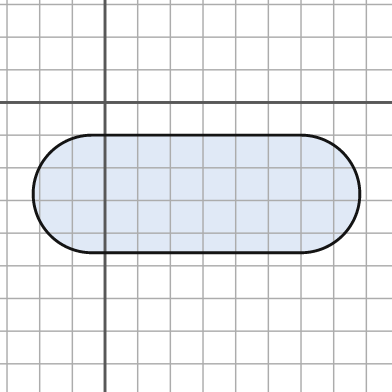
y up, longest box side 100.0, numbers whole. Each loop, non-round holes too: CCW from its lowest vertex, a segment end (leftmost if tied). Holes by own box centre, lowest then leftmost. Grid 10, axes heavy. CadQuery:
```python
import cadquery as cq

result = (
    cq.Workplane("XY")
    .moveTo(-4.0, -46.0)
    .lineTo(60.0, -46.0)
    .threePointArc((78.0, -28.0), (60.0, -10.0))
    .lineTo(-4.0, -10.0)
    .threePointArc((-22.0, -28.0), (-4.0, -46.0))
    .close()
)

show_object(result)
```